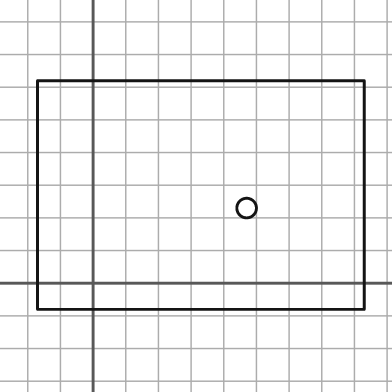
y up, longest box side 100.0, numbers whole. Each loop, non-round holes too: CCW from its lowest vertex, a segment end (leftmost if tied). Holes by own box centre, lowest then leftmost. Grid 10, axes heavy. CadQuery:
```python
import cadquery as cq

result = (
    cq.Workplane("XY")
    .moveTo(-17.0, -8.0)
    .lineTo(83.0, -8.0)
    .lineTo(83.0, 62.0)
    .lineTo(-17.0, 62.0)
    .close()
    .moveTo(47.0, 23.0)
    .circle(3.0)
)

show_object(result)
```